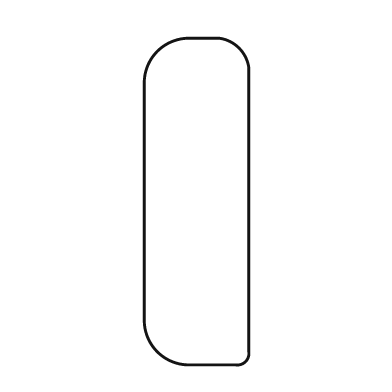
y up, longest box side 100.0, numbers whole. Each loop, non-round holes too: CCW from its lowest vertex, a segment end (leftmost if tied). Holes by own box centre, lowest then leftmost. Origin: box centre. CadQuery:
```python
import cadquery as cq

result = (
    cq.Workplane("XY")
    .moveTo(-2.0, -50.0)
    .lineTo(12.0, -50.0)
    .threePointArc((15.0, -49.0), (16.0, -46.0))
    .lineTo(16.0, 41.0)
    .threePointArc((13.0, 47.0), (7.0, 50.0))
    .lineTo(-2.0, 50.0)
    .threePointArc((-12.0, 46.0), (-16.0, 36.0))
    .lineTo(-16.0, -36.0)
    .threePointArc((-12.0, -46.0), (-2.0, -50.0))
    .close()
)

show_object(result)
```